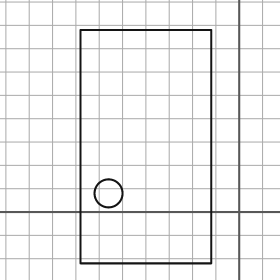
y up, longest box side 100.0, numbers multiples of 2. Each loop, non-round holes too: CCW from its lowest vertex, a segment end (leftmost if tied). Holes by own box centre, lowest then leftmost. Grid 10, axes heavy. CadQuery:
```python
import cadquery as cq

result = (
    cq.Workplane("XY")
    .moveTo(-68.0, -22.0)
    .lineTo(-12.0, -22.0)
    .lineTo(-12.0, 78.0)
    .lineTo(-68.0, 78.0)
    .close()
    .moveTo(-56.0, 8.0)
    .circle(6.0)
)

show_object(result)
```